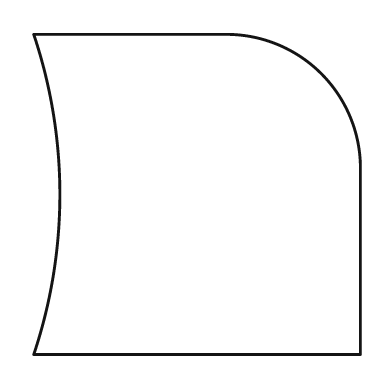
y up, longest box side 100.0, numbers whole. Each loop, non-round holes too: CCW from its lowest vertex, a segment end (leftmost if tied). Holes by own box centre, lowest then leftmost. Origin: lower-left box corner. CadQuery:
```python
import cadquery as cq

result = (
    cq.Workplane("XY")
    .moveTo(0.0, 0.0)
    .lineTo(100.0, 0.0)
    .lineTo(100.0, 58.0)
    .threePointArc((88.0, 86.0), (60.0, 98.0))
    .lineTo(0.0, 98.0)
    .threePointArc((8.0, 49.0), (0.0, 0.0))
    .close()
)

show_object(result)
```